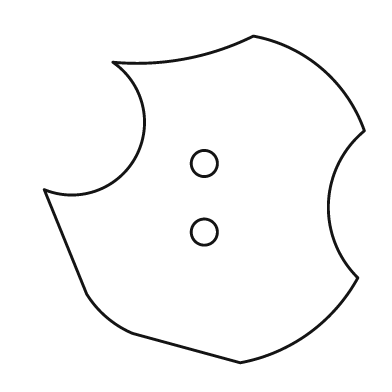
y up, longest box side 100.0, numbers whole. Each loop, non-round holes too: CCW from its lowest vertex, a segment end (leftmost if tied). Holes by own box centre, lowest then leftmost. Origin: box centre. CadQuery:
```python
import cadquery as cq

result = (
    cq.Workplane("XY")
    .moveTo(11.0, -50.0)
    .threePointArc((32.0, -41.0), (47.0, -24.0))
    .threePointArc((38.0, -1.0), (49.0, 21.0))
    .threePointArc((36.0, 40.0), (15.0, 50.0))
    .threePointArc((-6.0, 43.0), (-28.0, 42.0))
    .threePointArc((-21.0, 13.0), (-49.0, 3.0))
    .lineTo(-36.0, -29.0)
    .threePointArc((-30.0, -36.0), (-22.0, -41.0))
    .close()
    .moveTo(0.0, -10.0)
    .circle(4.0)
    .moveTo(0.0, 11.0)
    .circle(4.0)
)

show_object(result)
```